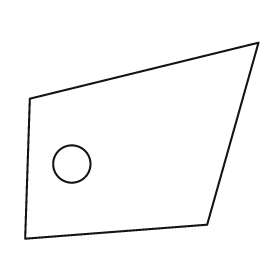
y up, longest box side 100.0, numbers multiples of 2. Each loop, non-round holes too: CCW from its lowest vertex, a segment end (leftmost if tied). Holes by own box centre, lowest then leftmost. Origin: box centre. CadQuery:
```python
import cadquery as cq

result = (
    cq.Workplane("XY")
    .moveTo(-50.0, -42.0)
    .lineTo(28.0, -36.0)
    .lineTo(50.0, 42.0)
    .lineTo(-48.0, 18.0)
    .close()
    .moveTo(-30.0, -10.0)
    .circle(8.0)
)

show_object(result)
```